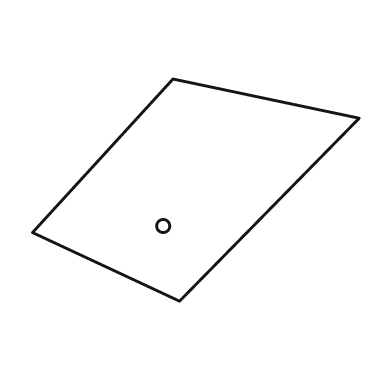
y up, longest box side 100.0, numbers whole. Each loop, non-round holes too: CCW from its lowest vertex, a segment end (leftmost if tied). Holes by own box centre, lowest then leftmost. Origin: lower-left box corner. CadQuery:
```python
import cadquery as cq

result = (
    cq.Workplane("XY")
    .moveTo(45.0, 0.0)
    .lineTo(100.0, 56.0)
    .lineTo(43.0, 68.0)
    .lineTo(0.0, 21.0)
    .close()
    .moveTo(40.0, 23.0)
    .circle(2.0)
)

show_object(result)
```